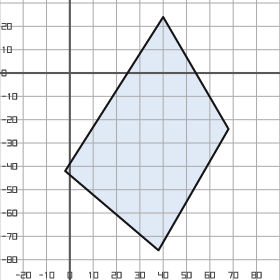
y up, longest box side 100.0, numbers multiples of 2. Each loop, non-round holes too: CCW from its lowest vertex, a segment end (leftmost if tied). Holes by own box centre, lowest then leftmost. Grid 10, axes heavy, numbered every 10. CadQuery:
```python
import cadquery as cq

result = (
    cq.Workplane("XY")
    .moveTo(38.0, -76.0)
    .lineTo(68.0, -24.0)
    .lineTo(40.0, 24.0)
    .lineTo(-2.0, -42.0)
    .close()
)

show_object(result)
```